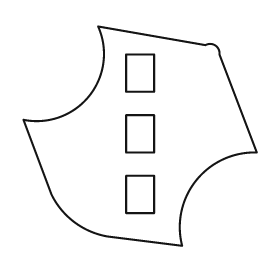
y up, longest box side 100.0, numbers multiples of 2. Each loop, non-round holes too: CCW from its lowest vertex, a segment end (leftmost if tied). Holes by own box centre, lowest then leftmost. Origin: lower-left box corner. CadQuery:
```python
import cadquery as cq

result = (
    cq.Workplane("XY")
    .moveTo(68.0, 0.0)
    .threePointArc((74.0, 28.0), (100.0, 40.0))
    .lineTo(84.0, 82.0)
    .threePointArc((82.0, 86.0), (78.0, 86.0))
    .lineTo(32.0, 94.0)
    .threePointArc((28.0, 64.0), (0.0, 54.0))
    .lineTo(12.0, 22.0)
    .threePointArc((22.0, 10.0), (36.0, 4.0))
    .close()
    .moveTo(44.0, 14.0)
    .lineTo(56.0, 14.0)
    .lineTo(56.0, 30.0)
    .lineTo(44.0, 30.0)
    .close()
    .moveTo(44.0, 40.0)
    .lineTo(56.0, 40.0)
    .lineTo(56.0, 56.0)
    .lineTo(44.0, 56.0)
    .close()
    .moveTo(44.0, 66.0)
    .lineTo(56.0, 66.0)
    .lineTo(56.0, 82.0)
    .lineTo(44.0, 82.0)
    .close()
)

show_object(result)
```